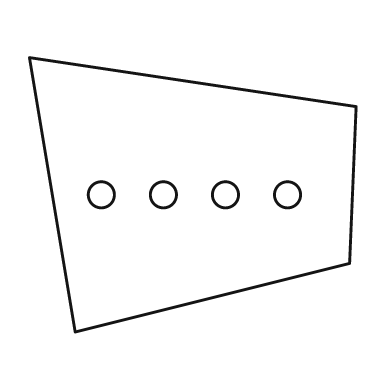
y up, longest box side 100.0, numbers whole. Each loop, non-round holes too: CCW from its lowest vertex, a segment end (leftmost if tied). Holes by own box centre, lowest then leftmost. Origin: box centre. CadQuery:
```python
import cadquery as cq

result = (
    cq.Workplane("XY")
    .moveTo(-36.0, -42.0)
    .lineTo(48.0, -21.0)
    .lineTo(50.0, 27.0)
    .lineTo(-50.0, 42.0)
    .close()
    .moveTo(-28.0, 0.0)
    .circle(4.0)
    .moveTo(-9.0, 0.0)
    .circle(4.0)
    .moveTo(10.0, 0.0)
    .circle(4.0)
    .moveTo(29.0, 0.0)
    .circle(4.0)
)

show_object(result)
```